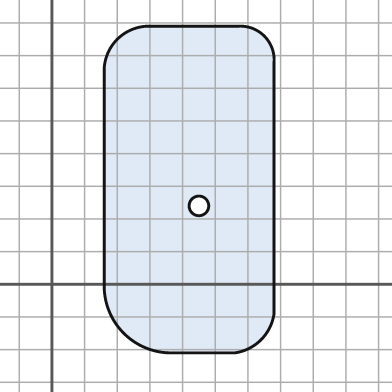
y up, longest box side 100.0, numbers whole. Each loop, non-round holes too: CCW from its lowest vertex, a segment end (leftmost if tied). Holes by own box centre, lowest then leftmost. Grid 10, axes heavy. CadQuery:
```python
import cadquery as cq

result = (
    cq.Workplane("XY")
    .moveTo(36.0, -21.0)
    .lineTo(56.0, -21.0)
    .threePointArc((64.0, -17.0), (68.0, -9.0))
    .lineTo(68.0, 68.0)
    .threePointArc((65.0, 76.0), (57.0, 79.0))
    .lineTo(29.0, 79.0)
    .threePointArc((20.0, 75.0), (16.0, 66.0))
    .lineTo(16.0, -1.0)
    .threePointArc((22.0, -15.0), (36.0, -21.0))
    .close()
    .moveTo(45.0, 24.0)
    .circle(3.0)
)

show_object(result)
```